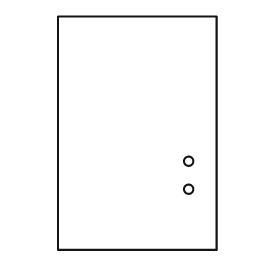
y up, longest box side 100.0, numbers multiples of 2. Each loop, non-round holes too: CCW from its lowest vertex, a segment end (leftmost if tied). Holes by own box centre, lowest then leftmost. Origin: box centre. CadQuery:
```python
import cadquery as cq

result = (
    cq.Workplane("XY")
    .moveTo(-34.0, -50.0)
    .lineTo(34.0, -50.0)
    .lineTo(34.0, 50.0)
    .lineTo(-34.0, 50.0)
    .close()
    .moveTo(22.0, -24.0)
    .circle(2.0)
    .moveTo(22.0, -12.0)
    .circle(2.0)
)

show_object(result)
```